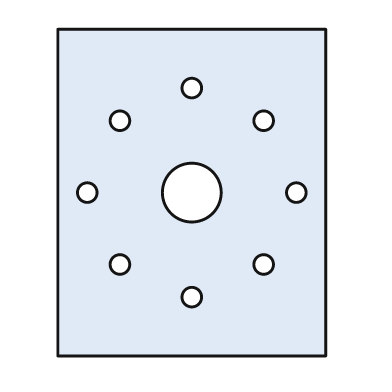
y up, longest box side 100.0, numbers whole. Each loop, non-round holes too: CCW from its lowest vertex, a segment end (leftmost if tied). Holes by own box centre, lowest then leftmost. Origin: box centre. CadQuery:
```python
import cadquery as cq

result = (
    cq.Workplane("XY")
    .moveTo(-41.0, -50.0)
    .lineTo(41.0, -50.0)
    .lineTo(41.0, 50.0)
    .lineTo(-41.0, 50.0)
    .close()
    .moveTo(0.0, -32.0)
    .circle(3.0)
    .moveTo(-22.0, -22.0)
    .circle(3.0)
    .moveTo(22.0, -22.0)
    .circle(3.0)
    .moveTo(-32.0, 0.0)
    .circle(3.0)
    .moveTo(0.0, 0.0)
    .circle(9.0)
    .moveTo(32.0, 0.0)
    .circle(3.0)
    .moveTo(-22.0, 22.0)
    .circle(3.0)
    .moveTo(22.0, 22.0)
    .circle(3.0)
    .moveTo(0.0, 32.0)
    .circle(3.0)
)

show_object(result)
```